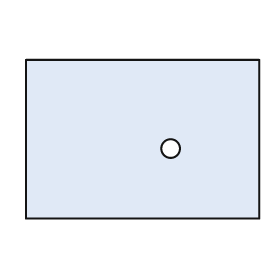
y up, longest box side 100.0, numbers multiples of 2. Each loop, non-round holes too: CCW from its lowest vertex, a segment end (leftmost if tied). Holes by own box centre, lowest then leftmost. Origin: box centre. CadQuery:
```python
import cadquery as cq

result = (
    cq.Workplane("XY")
    .moveTo(-50.0, -34.0)
    .lineTo(50.0, -34.0)
    .lineTo(50.0, 34.0)
    .lineTo(-50.0, 34.0)
    .close()
    .moveTo(12.0, -4.0)
    .circle(4.0)
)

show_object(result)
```